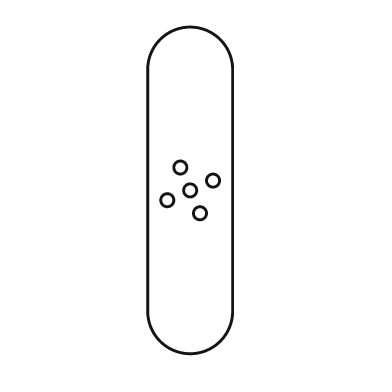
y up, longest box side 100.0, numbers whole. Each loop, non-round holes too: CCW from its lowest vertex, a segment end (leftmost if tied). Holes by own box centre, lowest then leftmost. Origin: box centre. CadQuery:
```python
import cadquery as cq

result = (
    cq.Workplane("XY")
    .moveTo(-13.0, -37.0)
    .threePointArc((0.0, -50.0), (13.0, -37.0))
    .lineTo(13.0, 37.0)
    .threePointArc((0.0, 50.0), (-13.0, 37.0))
    .close()
    .moveTo(3.0, -7.0)
    .circle(2.0)
    .moveTo(-7.0, -3.0)
    .circle(2.0)
    .moveTo(0.0, 0.0)
    .circle(2.0)
    .moveTo(7.0, 3.0)
    .circle(2.0)
    .moveTo(-3.0, 7.0)
    .circle(2.0)
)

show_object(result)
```